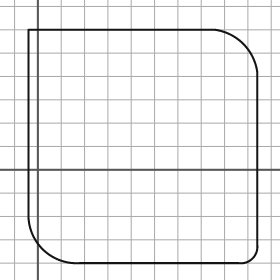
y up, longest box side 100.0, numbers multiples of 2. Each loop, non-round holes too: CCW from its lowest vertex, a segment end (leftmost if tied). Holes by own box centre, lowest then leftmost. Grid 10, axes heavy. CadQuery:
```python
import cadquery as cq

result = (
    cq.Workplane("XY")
    .moveTo(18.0, -40.0)
    .lineTo(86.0, -40.0)
    .threePointArc((92.0, -38.0), (94.0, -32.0))
    .lineTo(94.0, 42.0)
    .threePointArc((88.0, 54.0), (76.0, 60.0))
    .lineTo(-4.0, 60.0)
    .lineTo(-4.0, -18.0)
    .threePointArc((2.0, -34.0), (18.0, -40.0))
    .close()
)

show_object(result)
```